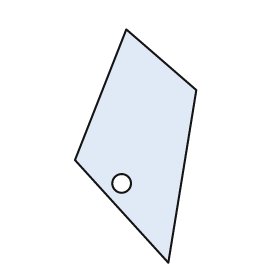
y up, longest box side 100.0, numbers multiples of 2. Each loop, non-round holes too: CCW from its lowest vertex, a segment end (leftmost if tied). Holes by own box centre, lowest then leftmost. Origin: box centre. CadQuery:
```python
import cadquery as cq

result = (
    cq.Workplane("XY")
    .moveTo(14.0, -50.0)
    .lineTo(26.0, 24.0)
    .lineTo(-4.0, 50.0)
    .lineTo(-26.0, -6.0)
    .close()
    .moveTo(-6.0, -16.0)
    .circle(4.0)
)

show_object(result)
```